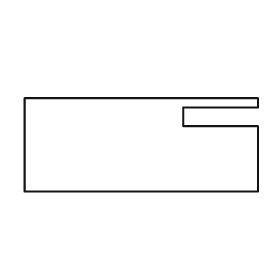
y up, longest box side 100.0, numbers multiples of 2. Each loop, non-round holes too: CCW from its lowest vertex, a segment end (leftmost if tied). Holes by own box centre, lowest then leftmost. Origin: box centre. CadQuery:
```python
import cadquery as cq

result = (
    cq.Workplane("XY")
    .moveTo(-50.0, -20.0)
    .lineTo(50.0, -20.0)
    .lineTo(50.0, 8.0)
    .lineTo(18.0, 8.0)
    .lineTo(18.0, 16.0)
    .lineTo(50.0, 16.0)
    .lineTo(50.0, 20.0)
    .lineTo(-50.0, 20.0)
    .close()
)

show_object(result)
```